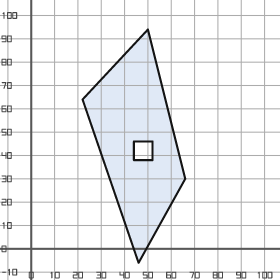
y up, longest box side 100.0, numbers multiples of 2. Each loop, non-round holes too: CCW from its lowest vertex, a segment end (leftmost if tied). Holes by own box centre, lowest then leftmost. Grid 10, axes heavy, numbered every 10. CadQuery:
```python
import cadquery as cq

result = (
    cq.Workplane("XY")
    .moveTo(46.0, -6.0)
    .lineTo(66.0, 30.0)
    .lineTo(50.0, 94.0)
    .lineTo(22.0, 64.0)
    .close()
    .moveTo(44.0, 38.0)
    .lineTo(52.0, 38.0)
    .lineTo(52.0, 46.0)
    .lineTo(44.0, 46.0)
    .close()
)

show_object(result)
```